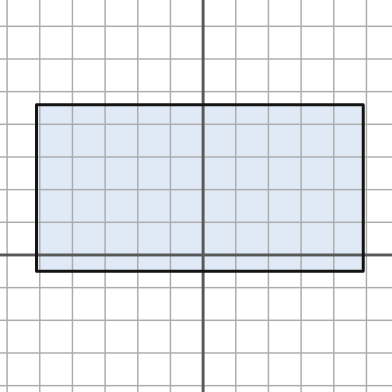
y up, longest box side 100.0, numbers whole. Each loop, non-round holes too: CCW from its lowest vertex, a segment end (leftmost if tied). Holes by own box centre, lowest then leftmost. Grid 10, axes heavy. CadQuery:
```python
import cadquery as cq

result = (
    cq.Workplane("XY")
    .moveTo(-51.0, -5.0)
    .lineTo(49.0, -5.0)
    .lineTo(49.0, 46.0)
    .lineTo(-51.0, 46.0)
    .close()
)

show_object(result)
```